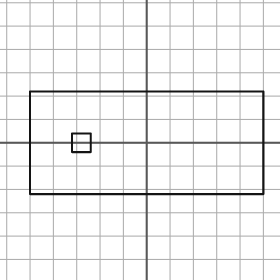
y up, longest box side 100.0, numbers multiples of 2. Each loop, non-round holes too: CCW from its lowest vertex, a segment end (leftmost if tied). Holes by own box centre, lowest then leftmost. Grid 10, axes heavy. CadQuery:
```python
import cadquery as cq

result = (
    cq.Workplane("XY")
    .moveTo(-50.0, -22.0)
    .lineTo(50.0, -22.0)
    .lineTo(50.0, 22.0)
    .lineTo(-50.0, 22.0)
    .close()
    .moveTo(-32.0, -4.0)
    .lineTo(-24.0, -4.0)
    .lineTo(-24.0, 4.0)
    .lineTo(-32.0, 4.0)
    .close()
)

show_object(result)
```